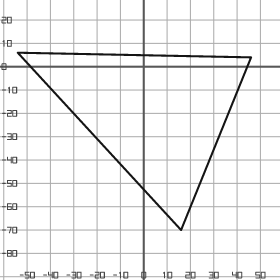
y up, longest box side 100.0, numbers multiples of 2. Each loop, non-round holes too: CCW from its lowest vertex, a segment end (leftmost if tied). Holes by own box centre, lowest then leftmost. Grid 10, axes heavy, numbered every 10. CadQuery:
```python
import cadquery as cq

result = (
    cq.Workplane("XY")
    .moveTo(16.0, -70.0)
    .lineTo(46.0, 4.0)
    .lineTo(-54.0, 6.0)
    .close()
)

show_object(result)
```